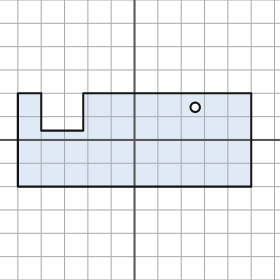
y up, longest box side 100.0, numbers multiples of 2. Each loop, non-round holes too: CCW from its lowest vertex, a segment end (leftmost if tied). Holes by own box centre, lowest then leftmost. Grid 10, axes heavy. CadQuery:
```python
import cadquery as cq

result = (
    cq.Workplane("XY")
    .moveTo(-50.0, -20.0)
    .lineTo(50.0, -20.0)
    .lineTo(50.0, 20.0)
    .lineTo(-22.0, 20.0)
    .lineTo(-22.0, 4.0)
    .lineTo(-40.0, 4.0)
    .lineTo(-40.0, 20.0)
    .lineTo(-50.0, 20.0)
    .close()
    .moveTo(26.0, 14.0)
    .circle(2.0)
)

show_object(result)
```